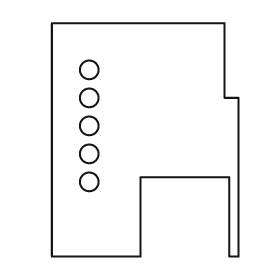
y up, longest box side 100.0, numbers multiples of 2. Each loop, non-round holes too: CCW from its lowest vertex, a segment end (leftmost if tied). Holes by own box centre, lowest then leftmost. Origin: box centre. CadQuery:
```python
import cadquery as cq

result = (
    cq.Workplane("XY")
    .moveTo(-40.0, -50.0)
    .lineTo(-2.0, -50.0)
    .lineTo(-2.0, -16.0)
    .lineTo(36.0, -16.0)
    .lineTo(36.0, -50.0)
    .lineTo(40.0, -50.0)
    .lineTo(40.0, 18.0)
    .lineTo(34.0, 18.0)
    .lineTo(34.0, 50.0)
    .lineTo(-40.0, 50.0)
    .close()
    .moveTo(-24.0, -18.0)
    .circle(4.0)
    .moveTo(-24.0, -6.0)
    .circle(4.0)
    .moveTo(-24.0, 6.0)
    .circle(4.0)
    .moveTo(-24.0, 18.0)
    .circle(4.0)
    .moveTo(-24.0, 30.0)
    .circle(4.0)
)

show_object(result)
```